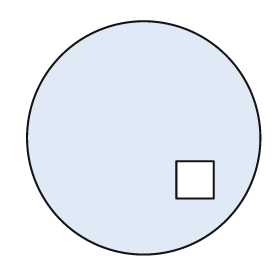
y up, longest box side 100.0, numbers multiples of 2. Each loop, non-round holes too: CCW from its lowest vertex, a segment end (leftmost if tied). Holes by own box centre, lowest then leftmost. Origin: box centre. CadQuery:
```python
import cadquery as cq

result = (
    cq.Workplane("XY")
    .moveTo(0.0, 0.0)
    .circle(50.0)
    .moveTo(14.0, -26.0)
    .lineTo(30.0, -26.0)
    .lineTo(30.0, -10.0)
    .lineTo(14.0, -10.0)
    .close()
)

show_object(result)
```